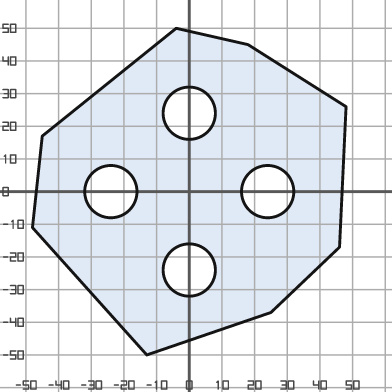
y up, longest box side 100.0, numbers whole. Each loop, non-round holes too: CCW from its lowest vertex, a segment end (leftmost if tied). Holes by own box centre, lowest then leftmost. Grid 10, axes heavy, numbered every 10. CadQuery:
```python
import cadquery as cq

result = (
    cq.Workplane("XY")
    .moveTo(-13.0, -50.0)
    .lineTo(25.0, -37.0)
    .lineTo(46.0, -17.0)
    .lineTo(48.0, 26.0)
    .lineTo(18.0, 45.0)
    .lineTo(-4.0, 50.0)
    .lineTo(-45.0, 17.0)
    .lineTo(-48.0, -11.0)
    .close()
    .moveTo(0.0, -24.0)
    .circle(8.0)
    .moveTo(-24.0, 0.0)
    .circle(8.0)
    .moveTo(24.0, 0.0)
    .circle(8.0)
    .moveTo(0.0, 24.0)
    .circle(8.0)
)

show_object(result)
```